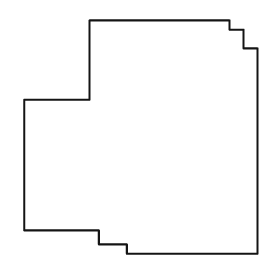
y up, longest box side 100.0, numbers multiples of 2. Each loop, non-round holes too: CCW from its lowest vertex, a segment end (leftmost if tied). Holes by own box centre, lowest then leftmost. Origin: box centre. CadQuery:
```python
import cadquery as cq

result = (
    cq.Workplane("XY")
    .moveTo(-6.0, -50.0)
    .lineTo(50.0, -50.0)
    .lineTo(50.0, 38.0)
    .lineTo(44.0, 38.0)
    .lineTo(44.0, 46.0)
    .lineTo(38.0, 46.0)
    .lineTo(38.0, 50.0)
    .lineTo(-22.0, 50.0)
    .lineTo(-22.0, 16.0)
    .lineTo(-50.0, 16.0)
    .lineTo(-50.0, -40.0)
    .lineTo(-18.0, -40.0)
    .lineTo(-18.0, -46.0)
    .lineTo(-6.0, -46.0)
    .close()
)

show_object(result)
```